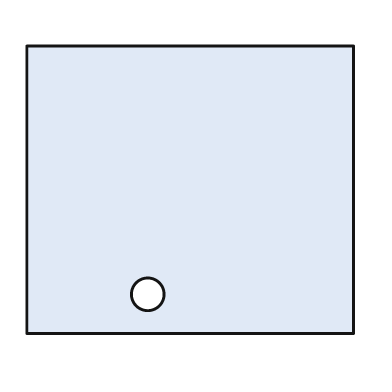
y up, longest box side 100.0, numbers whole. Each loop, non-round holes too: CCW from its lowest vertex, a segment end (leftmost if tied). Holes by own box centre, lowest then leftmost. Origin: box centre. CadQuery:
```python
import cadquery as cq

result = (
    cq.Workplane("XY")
    .moveTo(-50.0, -44.0)
    .lineTo(50.0, -44.0)
    .lineTo(50.0, 44.0)
    .lineTo(-50.0, 44.0)
    .close()
    .moveTo(-13.0, -32.0)
    .circle(5.0)
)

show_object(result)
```